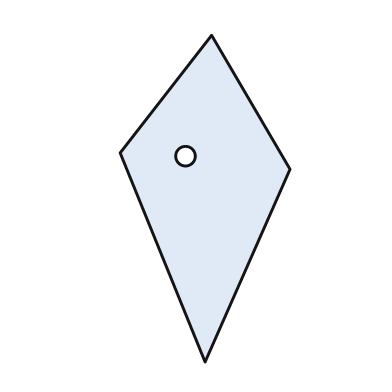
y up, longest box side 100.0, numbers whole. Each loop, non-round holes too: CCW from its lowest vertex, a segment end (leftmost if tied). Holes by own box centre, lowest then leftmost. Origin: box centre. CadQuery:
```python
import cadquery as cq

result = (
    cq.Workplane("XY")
    .moveTo(0.0, -50.0)
    .lineTo(26.0, 9.0)
    .lineTo(2.0, 50.0)
    .lineTo(-26.0, 14.0)
    .close()
    .moveTo(-6.0, 13.0)
    .circle(3.0)
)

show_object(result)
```